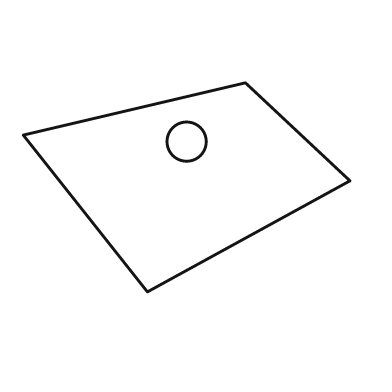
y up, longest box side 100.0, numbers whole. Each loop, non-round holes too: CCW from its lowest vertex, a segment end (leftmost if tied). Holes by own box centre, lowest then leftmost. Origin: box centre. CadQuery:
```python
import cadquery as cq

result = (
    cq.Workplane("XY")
    .moveTo(-12.0, -32.0)
    .lineTo(50.0, 2.0)
    .lineTo(18.0, 32.0)
    .lineTo(-50.0, 16.0)
    .close()
    .moveTo(0.0, 14.0)
    .circle(6.0)
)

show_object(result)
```